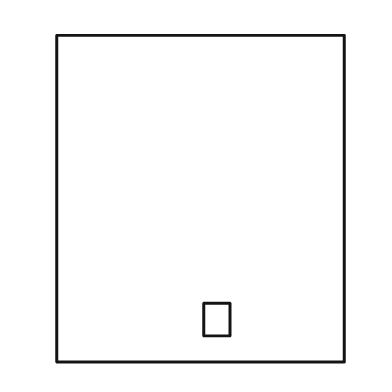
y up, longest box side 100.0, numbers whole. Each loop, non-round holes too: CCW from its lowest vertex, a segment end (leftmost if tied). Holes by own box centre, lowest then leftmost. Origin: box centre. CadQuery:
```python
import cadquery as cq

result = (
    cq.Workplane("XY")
    .moveTo(-44.0, -50.0)
    .lineTo(44.0, -50.0)
    .lineTo(44.0, 50.0)
    .lineTo(-44.0, 50.0)
    .close()
    .moveTo(1.0, -42.0)
    .lineTo(9.0, -42.0)
    .lineTo(9.0, -32.0)
    .lineTo(1.0, -32.0)
    .close()
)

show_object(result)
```